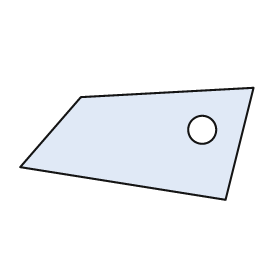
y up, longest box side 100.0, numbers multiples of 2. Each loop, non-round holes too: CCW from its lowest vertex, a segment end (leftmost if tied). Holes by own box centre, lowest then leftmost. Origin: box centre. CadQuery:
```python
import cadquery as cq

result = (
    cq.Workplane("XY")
    .moveTo(38.0, -24.0)
    .lineTo(50.0, 24.0)
    .lineTo(-24.0, 20.0)
    .lineTo(-50.0, -10.0)
    .close()
    .moveTo(28.0, 6.0)
    .circle(6.0)
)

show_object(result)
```